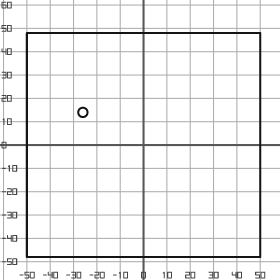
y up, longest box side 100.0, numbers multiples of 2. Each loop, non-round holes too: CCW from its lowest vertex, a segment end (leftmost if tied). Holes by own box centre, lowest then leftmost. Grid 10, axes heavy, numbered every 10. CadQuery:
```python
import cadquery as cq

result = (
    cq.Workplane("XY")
    .moveTo(-50.0, -48.0)
    .lineTo(50.0, -48.0)
    .lineTo(50.0, 48.0)
    .lineTo(-50.0, 48.0)
    .close()
    .moveTo(-26.0, 14.0)
    .circle(2.0)
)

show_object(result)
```